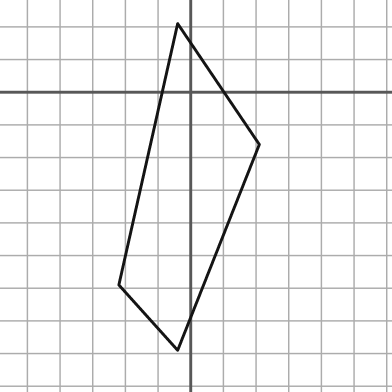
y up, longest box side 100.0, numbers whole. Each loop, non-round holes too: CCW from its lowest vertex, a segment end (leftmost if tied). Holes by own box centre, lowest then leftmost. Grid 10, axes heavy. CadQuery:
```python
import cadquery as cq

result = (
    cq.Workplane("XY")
    .moveTo(-4.0, -79.0)
    .lineTo(21.0, -16.0)
    .lineTo(-4.0, 21.0)
    .lineTo(-22.0, -59.0)
    .close()
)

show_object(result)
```